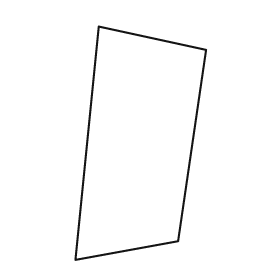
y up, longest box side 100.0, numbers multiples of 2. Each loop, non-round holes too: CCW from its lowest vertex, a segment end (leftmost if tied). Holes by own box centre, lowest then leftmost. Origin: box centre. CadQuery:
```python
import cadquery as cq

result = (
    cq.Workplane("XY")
    .moveTo(-28.0, -50.0)
    .lineTo(16.0, -42.0)
    .lineTo(28.0, 40.0)
    .lineTo(-18.0, 50.0)
    .close()
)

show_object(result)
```